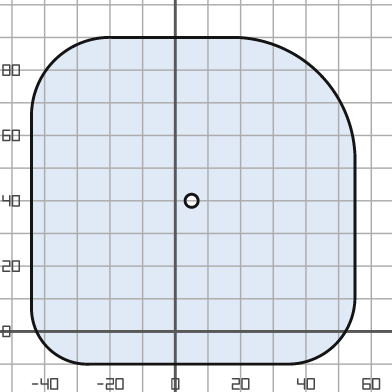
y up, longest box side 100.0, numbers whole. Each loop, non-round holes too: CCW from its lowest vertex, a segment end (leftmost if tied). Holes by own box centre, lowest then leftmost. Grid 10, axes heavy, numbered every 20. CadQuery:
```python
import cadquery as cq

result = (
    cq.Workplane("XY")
    .moveTo(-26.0, -10.0)
    .lineTo(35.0, -10.0)
    .threePointArc((49.0, -4.0), (55.0, 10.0))
    .lineTo(55.0, 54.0)
    .threePointArc((44.0, 79.0), (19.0, 90.0))
    .lineTo(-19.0, 90.0)
    .threePointArc((-37.0, 83.0), (-44.0, 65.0))
    .lineTo(-44.0, 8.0)
    .threePointArc((-39.0, -5.0), (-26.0, -10.0))
    .close()
    .moveTo(5.0, 40.0)
    .circle(2.0)
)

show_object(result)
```